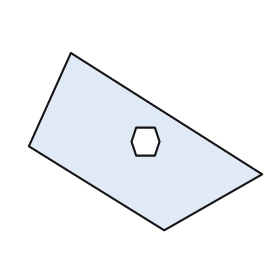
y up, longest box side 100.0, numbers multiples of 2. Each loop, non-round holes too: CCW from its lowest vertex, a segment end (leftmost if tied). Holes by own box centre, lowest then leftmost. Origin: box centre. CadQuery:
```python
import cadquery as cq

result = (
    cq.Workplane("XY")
    .moveTo(8.0, -38.0)
    .lineTo(50.0, -14.0)
    .lineTo(-32.0, 38.0)
    .lineTo(-50.0, -2.0)
    .close()
    .moveTo(-4.0, -6.0)
    .lineTo(4.0, -6.0)
    .lineTo(6.0, 0.0)
    .lineTo(4.0, 6.0)
    .lineTo(-4.0, 6.0)
    .lineTo(-6.0, 0.0)
    .close()
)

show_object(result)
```